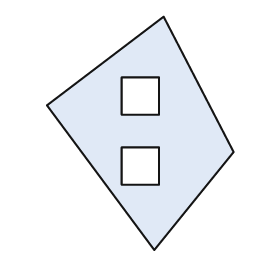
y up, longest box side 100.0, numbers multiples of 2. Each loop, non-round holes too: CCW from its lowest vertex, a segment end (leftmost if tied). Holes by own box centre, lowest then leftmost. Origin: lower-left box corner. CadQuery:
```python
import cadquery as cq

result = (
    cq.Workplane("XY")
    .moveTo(46.0, 0.0)
    .lineTo(80.0, 42.0)
    .lineTo(50.0, 100.0)
    .lineTo(0.0, 62.0)
    .close()
    .moveTo(32.0, 28.0)
    .lineTo(48.0, 28.0)
    .lineTo(48.0, 44.0)
    .lineTo(32.0, 44.0)
    .close()
    .moveTo(32.0, 58.0)
    .lineTo(48.0, 58.0)
    .lineTo(48.0, 74.0)
    .lineTo(32.0, 74.0)
    .close()
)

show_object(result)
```